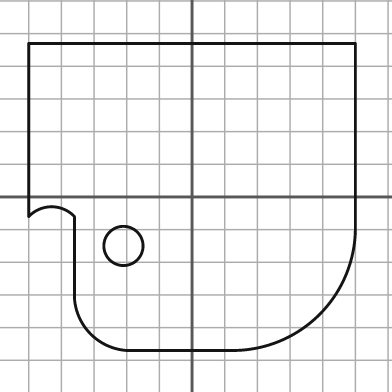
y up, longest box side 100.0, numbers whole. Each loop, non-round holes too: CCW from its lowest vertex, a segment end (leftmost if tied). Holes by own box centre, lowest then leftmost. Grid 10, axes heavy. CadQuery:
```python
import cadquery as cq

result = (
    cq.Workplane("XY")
    .moveTo(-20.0, -47.0)
    .lineTo(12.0, -47.0)
    .threePointArc((39.0, -36.0), (50.0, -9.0))
    .lineTo(50.0, 47.0)
    .lineTo(-50.0, 47.0)
    .lineTo(-50.0, -6.0)
    .threePointArc((-43.0, -3.0), (-36.0, -6.0))
    .lineTo(-36.0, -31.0)
    .threePointArc((-31.0, -42.0), (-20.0, -47.0))
    .close()
    .moveTo(-21.0, -15.0)
    .circle(6.0)
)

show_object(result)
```